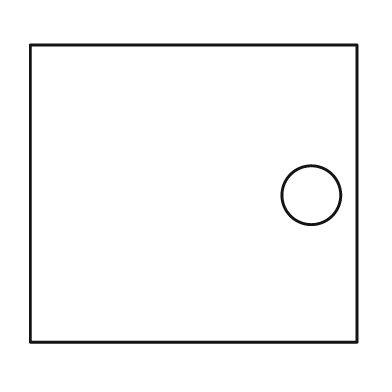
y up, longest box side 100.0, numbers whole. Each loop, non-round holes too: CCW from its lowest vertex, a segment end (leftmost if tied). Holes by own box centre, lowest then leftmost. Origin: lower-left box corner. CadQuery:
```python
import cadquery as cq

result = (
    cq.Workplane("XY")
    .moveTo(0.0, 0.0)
    .lineTo(100.0, 0.0)
    .lineTo(100.0, 91.0)
    .lineTo(0.0, 91.0)
    .close()
    .moveTo(86.0, 45.0)
    .circle(9.0)
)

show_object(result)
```